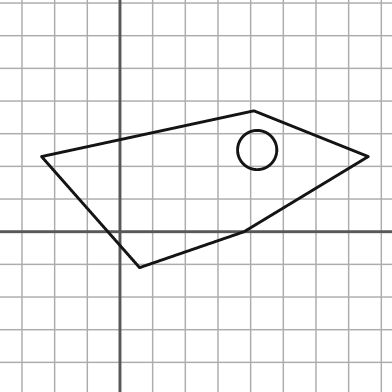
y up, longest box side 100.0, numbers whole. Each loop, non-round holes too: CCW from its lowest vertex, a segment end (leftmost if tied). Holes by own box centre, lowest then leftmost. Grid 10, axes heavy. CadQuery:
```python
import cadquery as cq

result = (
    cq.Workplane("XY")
    .moveTo(6.0, -11.0)
    .lineTo(38.0, 0.0)
    .lineTo(76.0, 23.0)
    .lineTo(41.0, 37.0)
    .lineTo(-24.0, 23.0)
    .close()
    .moveTo(42.0, 25.0)
    .circle(6.0)
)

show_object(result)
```